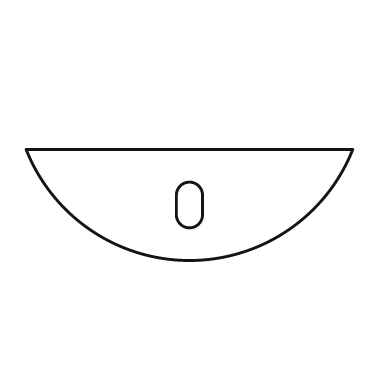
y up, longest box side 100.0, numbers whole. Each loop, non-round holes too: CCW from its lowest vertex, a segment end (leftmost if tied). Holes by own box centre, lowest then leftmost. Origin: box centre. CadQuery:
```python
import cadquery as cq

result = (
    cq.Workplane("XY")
    .moveTo(-50.0, 17.0)
    .threePointArc((0.0, -17.0), (50.0, 17.0))
    .close()
    .moveTo(-4.0, -3.0)
    .threePointArc((0.0, -7.0), (4.0, -3.0))
    .lineTo(4.0, 3.0)
    .threePointArc((0.0, 7.0), (-4.0, 3.0))
    .close()
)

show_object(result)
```